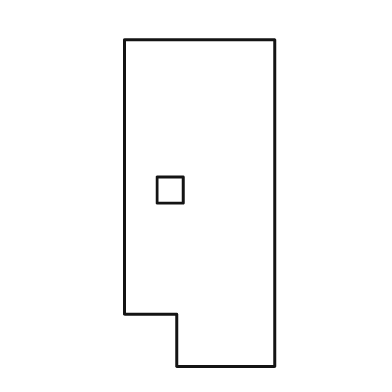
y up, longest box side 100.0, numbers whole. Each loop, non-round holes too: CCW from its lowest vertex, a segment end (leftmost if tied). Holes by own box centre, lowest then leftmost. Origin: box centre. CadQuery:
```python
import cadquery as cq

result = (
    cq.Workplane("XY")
    .moveTo(-7.0, -50.0)
    .lineTo(23.0, -50.0)
    .lineTo(23.0, 50.0)
    .lineTo(-23.0, 50.0)
    .lineTo(-23.0, -34.0)
    .lineTo(-7.0, -34.0)
    .close()
    .moveTo(-13.0, 0.0)
    .lineTo(-5.0, 0.0)
    .lineTo(-5.0, 8.0)
    .lineTo(-13.0, 8.0)
    .close()
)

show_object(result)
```